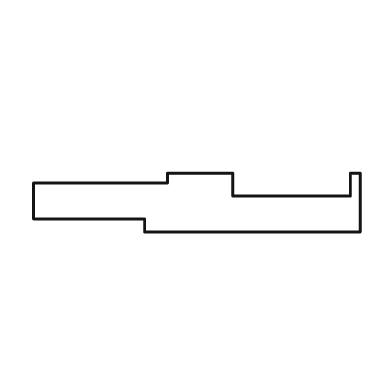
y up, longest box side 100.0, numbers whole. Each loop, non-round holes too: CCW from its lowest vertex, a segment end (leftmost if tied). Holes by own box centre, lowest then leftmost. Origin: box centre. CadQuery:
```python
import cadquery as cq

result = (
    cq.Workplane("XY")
    .moveTo(-16.0, -9.0)
    .lineTo(50.0, -9.0)
    .lineTo(50.0, 9.0)
    .lineTo(47.0, 9.0)
    .lineTo(47.0, 2.0)
    .lineTo(11.0, 2.0)
    .lineTo(11.0, 9.0)
    .lineTo(-9.0, 9.0)
    .lineTo(-9.0, 6.0)
    .lineTo(-50.0, 6.0)
    .lineTo(-50.0, -5.0)
    .lineTo(-16.0, -5.0)
    .close()
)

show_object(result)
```